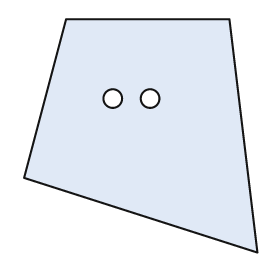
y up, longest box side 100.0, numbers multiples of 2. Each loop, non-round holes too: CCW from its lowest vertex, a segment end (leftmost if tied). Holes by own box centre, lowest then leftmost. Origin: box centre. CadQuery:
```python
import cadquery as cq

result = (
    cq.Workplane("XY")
    .moveTo(50.0, -50.0)
    .lineTo(38.0, 50.0)
    .lineTo(-32.0, 50.0)
    .lineTo(-50.0, -18.0)
    .close()
    .moveTo(-12.0, 16.0)
    .circle(4.0)
    .moveTo(4.0, 16.0)
    .circle(4.0)
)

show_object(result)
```